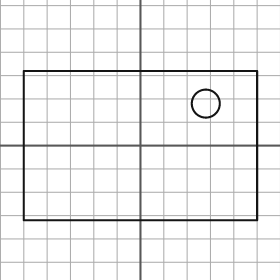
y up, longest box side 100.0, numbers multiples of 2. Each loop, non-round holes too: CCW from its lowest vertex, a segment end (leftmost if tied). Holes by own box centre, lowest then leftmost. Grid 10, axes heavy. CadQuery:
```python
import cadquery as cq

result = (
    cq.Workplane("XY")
    .moveTo(-50.0, -32.0)
    .lineTo(50.0, -32.0)
    .lineTo(50.0, 32.0)
    .lineTo(-50.0, 32.0)
    .close()
    .moveTo(28.0, 18.0)
    .circle(6.0)
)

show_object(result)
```